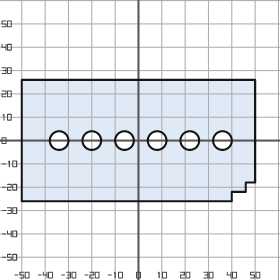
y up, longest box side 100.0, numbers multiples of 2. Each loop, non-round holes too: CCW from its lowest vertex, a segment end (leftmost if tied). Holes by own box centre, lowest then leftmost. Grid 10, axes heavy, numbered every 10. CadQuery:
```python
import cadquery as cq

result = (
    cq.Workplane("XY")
    .moveTo(-50.0, -26.0)
    .lineTo(40.0, -26.0)
    .lineTo(40.0, -22.0)
    .lineTo(46.0, -22.0)
    .lineTo(46.0, -18.0)
    .lineTo(50.0, -18.0)
    .lineTo(50.0, 26.0)
    .lineTo(-50.0, 26.0)
    .close()
    .moveTo(-34.0, 0.0)
    .circle(4.0)
    .moveTo(-20.0, 0.0)
    .circle(4.0)
    .moveTo(-6.0, 0.0)
    .circle(4.0)
    .moveTo(8.0, 0.0)
    .circle(4.0)
    .moveTo(22.0, 0.0)
    .circle(4.0)
    .moveTo(36.0, 0.0)
    .circle(4.0)
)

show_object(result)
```